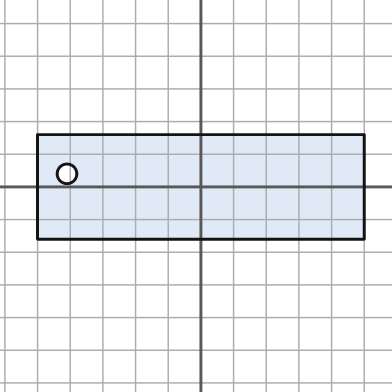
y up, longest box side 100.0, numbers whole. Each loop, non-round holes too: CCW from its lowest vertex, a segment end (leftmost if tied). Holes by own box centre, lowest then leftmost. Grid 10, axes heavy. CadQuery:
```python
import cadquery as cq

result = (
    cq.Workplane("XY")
    .moveTo(-50.0, -16.0)
    .lineTo(50.0, -16.0)
    .lineTo(50.0, 16.0)
    .lineTo(-50.0, 16.0)
    .close()
    .moveTo(-41.0, 4.0)
    .circle(3.0)
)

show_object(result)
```